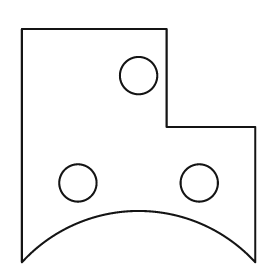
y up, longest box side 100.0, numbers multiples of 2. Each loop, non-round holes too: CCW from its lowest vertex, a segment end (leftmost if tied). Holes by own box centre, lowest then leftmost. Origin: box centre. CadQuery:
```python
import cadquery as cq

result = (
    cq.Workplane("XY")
    .moveTo(-50.0, -50.0)
    .threePointArc((0.0, -28.0), (50.0, -50.0))
    .lineTo(50.0, 8.0)
    .lineTo(12.0, 8.0)
    .lineTo(12.0, 50.0)
    .lineTo(-50.0, 50.0)
    .close()
    .moveTo(-26.0, -16.0)
    .circle(8.0)
    .moveTo(26.0, -16.0)
    .circle(8.0)
    .moveTo(0.0, 30.0)
    .circle(8.0)
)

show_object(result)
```